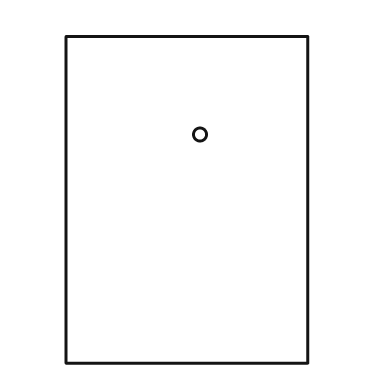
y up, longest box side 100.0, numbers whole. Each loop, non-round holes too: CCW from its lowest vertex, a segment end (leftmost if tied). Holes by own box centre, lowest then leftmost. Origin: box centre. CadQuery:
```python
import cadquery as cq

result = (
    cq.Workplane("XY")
    .moveTo(-37.0, -50.0)
    .lineTo(37.0, -50.0)
    .lineTo(37.0, 50.0)
    .lineTo(-37.0, 50.0)
    .close()
    .moveTo(4.0, 20.0)
    .circle(2.0)
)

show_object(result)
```